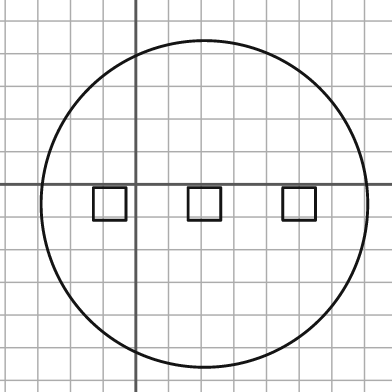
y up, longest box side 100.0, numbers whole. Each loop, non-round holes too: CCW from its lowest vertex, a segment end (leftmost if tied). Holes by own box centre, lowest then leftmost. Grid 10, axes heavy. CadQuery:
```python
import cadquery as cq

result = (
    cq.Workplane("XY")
    .moveTo(21.0, -6.0)
    .circle(50.0)
    .moveTo(-13.0, -11.0)
    .lineTo(-3.0, -11.0)
    .lineTo(-3.0, -1.0)
    .lineTo(-13.0, -1.0)
    .close()
    .moveTo(16.0, -11.0)
    .lineTo(26.0, -11.0)
    .lineTo(26.0, -1.0)
    .lineTo(16.0, -1.0)
    .close()
    .moveTo(45.0, -11.0)
    .lineTo(55.0, -11.0)
    .lineTo(55.0, -1.0)
    .lineTo(45.0, -1.0)
    .close()
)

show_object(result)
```